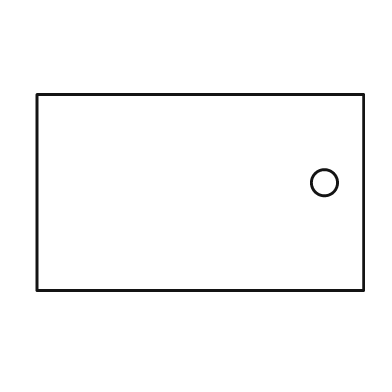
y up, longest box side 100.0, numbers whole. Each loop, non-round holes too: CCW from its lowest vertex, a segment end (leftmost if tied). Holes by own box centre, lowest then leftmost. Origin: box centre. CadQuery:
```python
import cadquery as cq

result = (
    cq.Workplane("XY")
    .moveTo(-50.0, -30.0)
    .lineTo(50.0, -30.0)
    .lineTo(50.0, 30.0)
    .lineTo(-50.0, 30.0)
    .close()
    .moveTo(38.0, 3.0)
    .circle(4.0)
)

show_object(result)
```